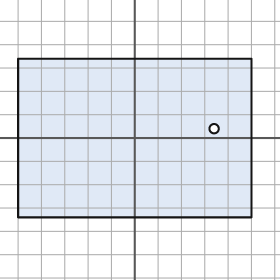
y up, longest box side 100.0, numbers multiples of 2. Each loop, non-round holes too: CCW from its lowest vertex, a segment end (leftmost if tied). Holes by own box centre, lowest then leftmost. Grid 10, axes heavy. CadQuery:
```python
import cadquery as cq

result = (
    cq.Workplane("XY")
    .moveTo(-50.0, -34.0)
    .lineTo(50.0, -34.0)
    .lineTo(50.0, 34.0)
    .lineTo(-50.0, 34.0)
    .close()
    .moveTo(34.0, 4.0)
    .circle(2.0)
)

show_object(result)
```